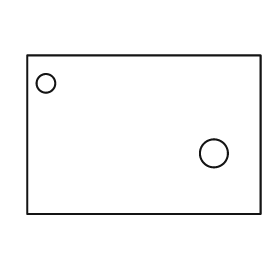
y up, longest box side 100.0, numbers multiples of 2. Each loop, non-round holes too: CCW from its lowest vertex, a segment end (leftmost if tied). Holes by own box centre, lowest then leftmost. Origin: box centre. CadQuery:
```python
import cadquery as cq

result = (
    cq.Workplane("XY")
    .moveTo(-50.0, -34.0)
    .lineTo(50.0, -34.0)
    .lineTo(50.0, 34.0)
    .lineTo(-50.0, 34.0)
    .close()
    .moveTo(30.0, -8.0)
    .circle(6.0)
    .moveTo(-42.0, 22.0)
    .circle(4.0)
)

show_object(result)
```